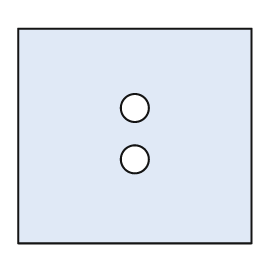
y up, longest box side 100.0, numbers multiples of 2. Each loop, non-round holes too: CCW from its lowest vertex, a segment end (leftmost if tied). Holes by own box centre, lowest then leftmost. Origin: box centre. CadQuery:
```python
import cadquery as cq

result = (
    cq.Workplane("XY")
    .moveTo(-50.0, -46.0)
    .lineTo(50.0, -46.0)
    .lineTo(50.0, 46.0)
    .lineTo(-50.0, 46.0)
    .close()
    .moveTo(0.0, -10.0)
    .circle(6.0)
    .moveTo(0.0, 12.0)
    .circle(6.0)
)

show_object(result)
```